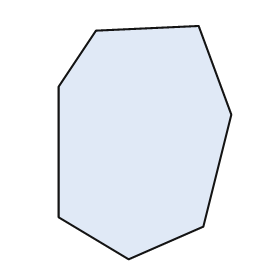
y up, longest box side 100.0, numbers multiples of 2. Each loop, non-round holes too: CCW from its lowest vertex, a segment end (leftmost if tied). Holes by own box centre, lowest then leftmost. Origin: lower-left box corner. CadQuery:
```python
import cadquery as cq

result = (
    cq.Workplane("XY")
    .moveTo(30.0, 0.0)
    .lineTo(62.0, 14.0)
    .lineTo(74.0, 62.0)
    .lineTo(60.0, 100.0)
    .lineTo(16.0, 98.0)
    .lineTo(0.0, 74.0)
    .lineTo(0.0, 18.0)
    .close()
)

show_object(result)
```